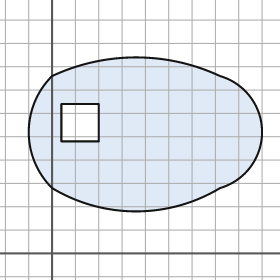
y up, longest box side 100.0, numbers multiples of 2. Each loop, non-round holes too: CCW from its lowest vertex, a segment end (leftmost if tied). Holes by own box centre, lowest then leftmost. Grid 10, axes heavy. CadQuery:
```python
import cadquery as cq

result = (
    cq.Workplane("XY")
    .moveTo(0.0, 28.0)
    .threePointArc((36.0, 18.0), (72.0, 28.0))
    .threePointArc((90.0, 52.0), (72.0, 76.0))
    .threePointArc((36.0, 84.0), (0.0, 76.0))
    .threePointArc((-10.0, 52.0), (0.0, 28.0))
    .close()
    .moveTo(4.0, 48.0)
    .lineTo(20.0, 48.0)
    .lineTo(20.0, 64.0)
    .lineTo(4.0, 64.0)
    .close()
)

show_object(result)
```